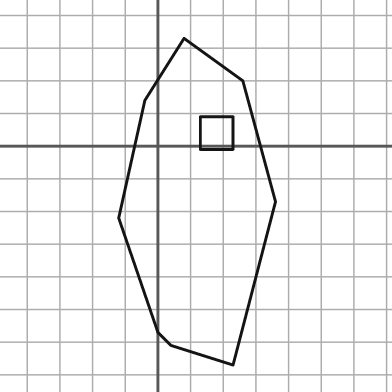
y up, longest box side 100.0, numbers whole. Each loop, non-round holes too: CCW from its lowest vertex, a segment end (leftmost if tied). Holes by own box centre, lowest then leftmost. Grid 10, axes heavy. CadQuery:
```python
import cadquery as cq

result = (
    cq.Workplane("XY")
    .moveTo(23.0, -67.0)
    .lineTo(36.0, -17.0)
    .lineTo(26.0, 20.0)
    .lineTo(8.0, 33.0)
    .lineTo(-4.0, 14.0)
    .lineTo(-12.0, -22.0)
    .lineTo(0.0, -57.0)
    .lineTo(4.0, -61.0)
    .close()
    .moveTo(13.0, -1.0)
    .lineTo(23.0, -1.0)
    .lineTo(23.0, 9.0)
    .lineTo(13.0, 9.0)
    .close()
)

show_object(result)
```